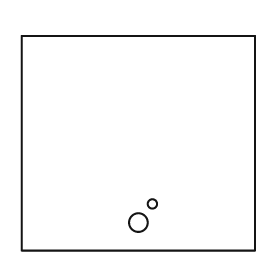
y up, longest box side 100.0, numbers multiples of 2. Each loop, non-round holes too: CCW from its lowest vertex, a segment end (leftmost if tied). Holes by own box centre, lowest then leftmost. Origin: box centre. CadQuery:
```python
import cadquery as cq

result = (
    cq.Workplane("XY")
    .moveTo(-50.0, -46.0)
    .lineTo(50.0, -46.0)
    .lineTo(50.0, 46.0)
    .lineTo(-50.0, 46.0)
    .close()
    .moveTo(0.0, -34.0)
    .circle(4.0)
    .moveTo(6.0, -26.0)
    .circle(2.0)
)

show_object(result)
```